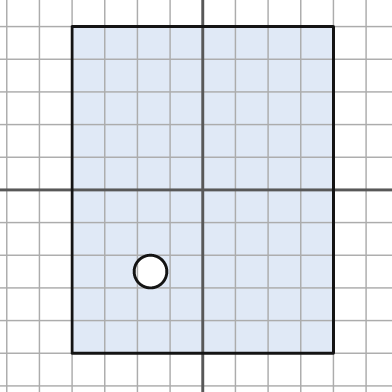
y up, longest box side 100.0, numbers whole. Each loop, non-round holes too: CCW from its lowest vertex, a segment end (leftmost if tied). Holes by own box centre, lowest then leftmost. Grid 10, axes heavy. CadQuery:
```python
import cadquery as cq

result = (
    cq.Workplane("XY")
    .moveTo(-40.0, -50.0)
    .lineTo(40.0, -50.0)
    .lineTo(40.0, 50.0)
    .lineTo(-40.0, 50.0)
    .close()
    .moveTo(-16.0, -25.0)
    .circle(5.0)
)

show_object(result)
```